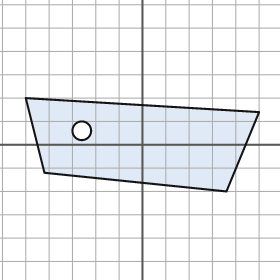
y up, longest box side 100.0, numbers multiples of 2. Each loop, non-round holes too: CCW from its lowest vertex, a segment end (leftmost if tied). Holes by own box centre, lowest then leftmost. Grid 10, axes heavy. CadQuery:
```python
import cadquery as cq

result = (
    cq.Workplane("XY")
    .moveTo(36.0, -20.0)
    .lineTo(50.0, 14.0)
    .lineTo(-50.0, 20.0)
    .lineTo(-42.0, -12.0)
    .close()
    .moveTo(-26.0, 6.0)
    .circle(4.0)
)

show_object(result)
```